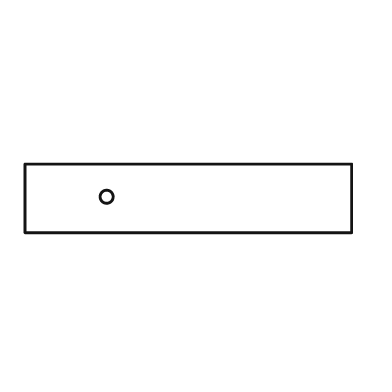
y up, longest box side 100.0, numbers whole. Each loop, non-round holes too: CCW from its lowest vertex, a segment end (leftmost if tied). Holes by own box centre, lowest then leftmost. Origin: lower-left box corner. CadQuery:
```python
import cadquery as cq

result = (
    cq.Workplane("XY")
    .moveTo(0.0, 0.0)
    .lineTo(100.0, 0.0)
    .lineTo(100.0, 21.0)
    .lineTo(0.0, 21.0)
    .close()
    .moveTo(25.0, 11.0)
    .circle(2.0)
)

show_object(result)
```